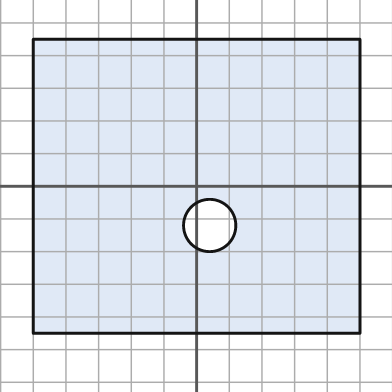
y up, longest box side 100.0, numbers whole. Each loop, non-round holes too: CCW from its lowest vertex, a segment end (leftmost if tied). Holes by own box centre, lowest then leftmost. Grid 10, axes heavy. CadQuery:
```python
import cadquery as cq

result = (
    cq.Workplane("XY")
    .moveTo(-50.0, -45.0)
    .lineTo(50.0, -45.0)
    .lineTo(50.0, 45.0)
    .lineTo(-50.0, 45.0)
    .close()
    .moveTo(4.0, -12.0)
    .circle(8.0)
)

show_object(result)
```